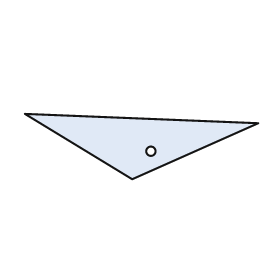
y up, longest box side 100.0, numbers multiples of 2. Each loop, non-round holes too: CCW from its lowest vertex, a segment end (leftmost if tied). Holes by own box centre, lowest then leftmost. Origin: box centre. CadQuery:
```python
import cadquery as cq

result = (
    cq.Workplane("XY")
    .moveTo(-4.0, -14.0)
    .lineTo(50.0, 10.0)
    .lineTo(-50.0, 14.0)
    .close()
    .moveTo(4.0, -2.0)
    .circle(2.0)
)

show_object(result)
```